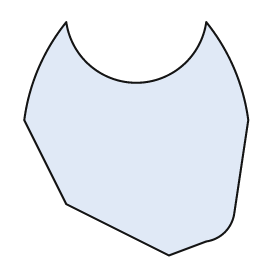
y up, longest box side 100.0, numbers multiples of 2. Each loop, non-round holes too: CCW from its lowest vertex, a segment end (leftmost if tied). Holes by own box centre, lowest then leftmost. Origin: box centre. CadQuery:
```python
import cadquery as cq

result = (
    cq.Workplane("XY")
    .moveTo(14.0, -50.0)
    .lineTo(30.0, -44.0)
    .threePointArc((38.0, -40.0), (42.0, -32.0))
    .lineTo(48.0, 8.0)
    .threePointArc((42.0, 30.0), (30.0, 50.0))
    .threePointArc((0.0, 24.0), (-30.0, 50.0))
    .threePointArc((-42.0, 30.0), (-48.0, 8.0))
    .lineTo(-30.0, -28.0)
    .close()
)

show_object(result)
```